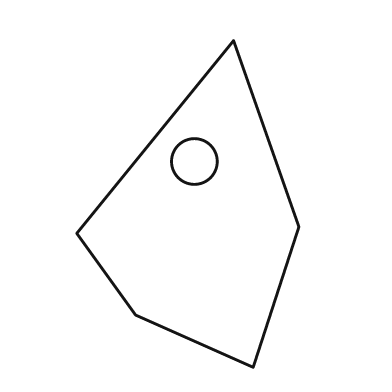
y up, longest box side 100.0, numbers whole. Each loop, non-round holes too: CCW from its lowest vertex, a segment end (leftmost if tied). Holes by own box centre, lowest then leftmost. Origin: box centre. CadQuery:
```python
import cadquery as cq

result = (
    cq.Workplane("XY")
    .moveTo(20.0, -50.0)
    .lineTo(34.0, -7.0)
    .lineTo(14.0, 50.0)
    .lineTo(-34.0, -9.0)
    .lineTo(-16.0, -34.0)
    .close()
    .moveTo(2.0, 13.0)
    .circle(7.0)
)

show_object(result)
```